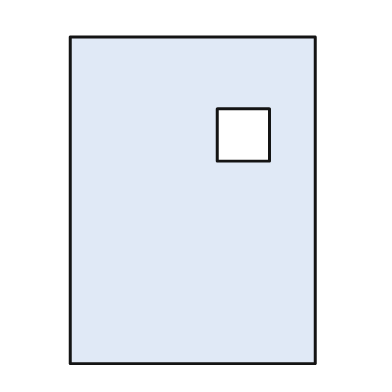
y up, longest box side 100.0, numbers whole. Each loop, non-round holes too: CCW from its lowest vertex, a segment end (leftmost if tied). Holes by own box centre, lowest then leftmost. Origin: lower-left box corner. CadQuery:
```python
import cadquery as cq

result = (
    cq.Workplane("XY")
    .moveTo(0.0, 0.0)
    .lineTo(75.0, 0.0)
    .lineTo(75.0, 100.0)
    .lineTo(0.0, 100.0)
    .close()
    .moveTo(45.0, 62.0)
    .lineTo(61.0, 62.0)
    .lineTo(61.0, 78.0)
    .lineTo(45.0, 78.0)
    .close()
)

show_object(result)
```